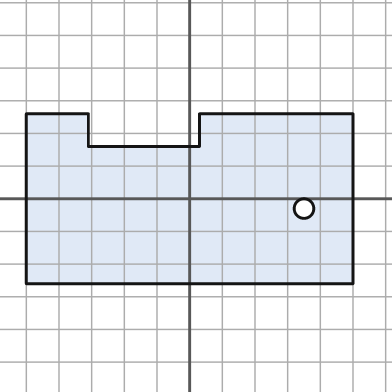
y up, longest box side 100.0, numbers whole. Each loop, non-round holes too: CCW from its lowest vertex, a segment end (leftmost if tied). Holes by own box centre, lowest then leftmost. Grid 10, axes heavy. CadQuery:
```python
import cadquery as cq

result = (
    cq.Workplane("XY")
    .moveTo(-50.0, -26.0)
    .lineTo(50.0, -26.0)
    .lineTo(50.0, 26.0)
    .lineTo(3.0, 26.0)
    .lineTo(3.0, 16.0)
    .lineTo(-31.0, 16.0)
    .lineTo(-31.0, 26.0)
    .lineTo(-50.0, 26.0)
    .close()
    .moveTo(35.0, -3.0)
    .circle(3.0)
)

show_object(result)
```